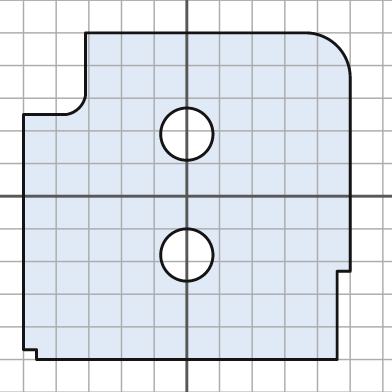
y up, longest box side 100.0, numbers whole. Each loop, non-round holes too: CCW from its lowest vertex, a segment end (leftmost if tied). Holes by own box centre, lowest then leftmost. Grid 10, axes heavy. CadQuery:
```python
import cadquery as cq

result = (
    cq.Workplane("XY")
    .moveTo(-46.0, -50.0)
    .lineTo(46.0, -50.0)
    .lineTo(46.0, -23.0)
    .lineTo(50.0, -23.0)
    .lineTo(50.0, 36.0)
    .threePointArc((46.0, 46.0), (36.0, 50.0))
    .lineTo(-31.0, 50.0)
    .lineTo(-31.0, 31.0)
    .threePointArc((-33.0, 27.0), (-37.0, 25.0))
    .lineTo(-50.0, 25.0)
    .lineTo(-50.0, -47.0)
    .lineTo(-46.0, -47.0)
    .close()
    .moveTo(0.0, -18.0)
    .circle(8.0)
    .moveTo(0.0, 19.0)
    .circle(8.0)
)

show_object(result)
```